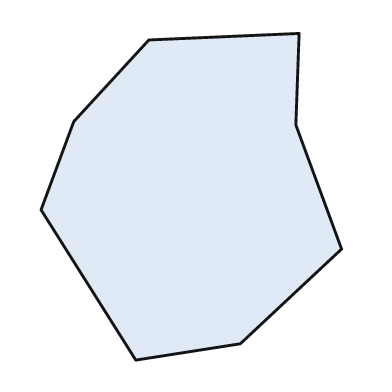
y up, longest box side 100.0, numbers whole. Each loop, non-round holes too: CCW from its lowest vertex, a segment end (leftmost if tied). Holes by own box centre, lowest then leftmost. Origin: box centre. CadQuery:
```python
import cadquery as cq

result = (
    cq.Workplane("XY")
    .moveTo(-17.0, -50.0)
    .lineTo(15.0, -45.0)
    .lineTo(46.0, -16.0)
    .lineTo(32.0, 22.0)
    .lineTo(33.0, 50.0)
    .lineTo(-13.0, 48.0)
    .lineTo(-36.0, 23.0)
    .lineTo(-46.0, -4.0)
    .close()
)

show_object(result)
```